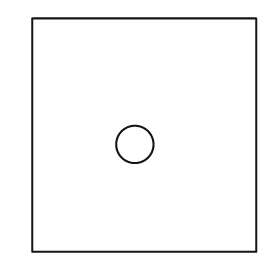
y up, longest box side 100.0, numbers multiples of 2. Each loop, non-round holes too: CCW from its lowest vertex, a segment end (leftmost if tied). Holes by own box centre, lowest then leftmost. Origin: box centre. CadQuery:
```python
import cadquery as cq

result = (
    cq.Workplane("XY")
    .moveTo(-48.0, -50.0)
    .lineTo(48.0, -50.0)
    .lineTo(48.0, 50.0)
    .lineTo(-48.0, 50.0)
    .close()
    .moveTo(-4.0, -4.0)
    .circle(8.0)
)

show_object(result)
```